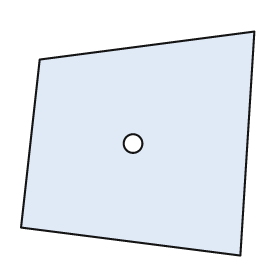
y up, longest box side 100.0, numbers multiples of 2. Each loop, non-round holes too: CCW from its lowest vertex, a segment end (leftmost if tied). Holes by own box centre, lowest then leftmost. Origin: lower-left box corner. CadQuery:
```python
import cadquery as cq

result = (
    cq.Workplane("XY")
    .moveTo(94.0, 0.0)
    .lineTo(100.0, 96.0)
    .lineTo(8.0, 84.0)
    .lineTo(0.0, 12.0)
    .close()
    .moveTo(48.0, 48.0)
    .circle(4.0)
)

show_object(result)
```